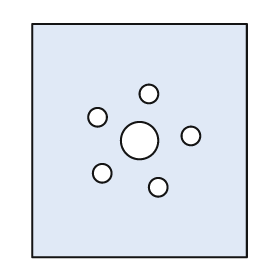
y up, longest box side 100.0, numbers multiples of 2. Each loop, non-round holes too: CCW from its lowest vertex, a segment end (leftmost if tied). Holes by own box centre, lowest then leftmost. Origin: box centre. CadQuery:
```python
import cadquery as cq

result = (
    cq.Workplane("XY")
    .moveTo(-46.0, -50.0)
    .lineTo(46.0, -50.0)
    .lineTo(46.0, 50.0)
    .lineTo(-46.0, 50.0)
    .close()
    .moveTo(8.0, -20.0)
    .circle(4.0)
    .moveTo(-16.0, -14.0)
    .circle(4.0)
    .moveTo(0.0, 0.0)
    .circle(8.0)
    .moveTo(22.0, 2.0)
    .circle(4.0)
    .moveTo(-18.0, 10.0)
    .circle(4.0)
    .moveTo(4.0, 20.0)
    .circle(4.0)
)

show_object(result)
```